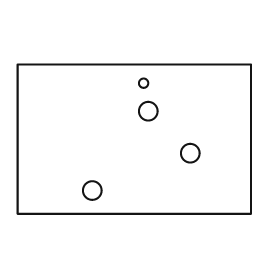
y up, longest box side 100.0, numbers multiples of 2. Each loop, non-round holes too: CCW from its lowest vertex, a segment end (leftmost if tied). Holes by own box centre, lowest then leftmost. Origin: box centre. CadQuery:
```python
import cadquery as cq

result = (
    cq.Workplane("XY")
    .moveTo(-50.0, -32.0)
    .lineTo(50.0, -32.0)
    .lineTo(50.0, 32.0)
    .lineTo(-50.0, 32.0)
    .close()
    .moveTo(-18.0, -22.0)
    .circle(4.0)
    .moveTo(24.0, -6.0)
    .circle(4.0)
    .moveTo(6.0, 12.0)
    .circle(4.0)
    .moveTo(4.0, 24.0)
    .circle(2.0)
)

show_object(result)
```